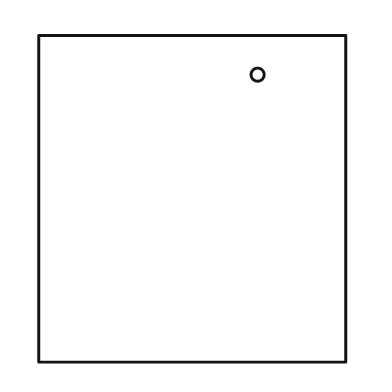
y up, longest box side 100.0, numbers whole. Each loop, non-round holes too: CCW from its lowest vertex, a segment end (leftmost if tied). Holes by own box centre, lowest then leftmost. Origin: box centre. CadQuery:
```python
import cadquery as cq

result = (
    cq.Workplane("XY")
    .moveTo(-47.0, -50.0)
    .lineTo(47.0, -50.0)
    .lineTo(47.0, 50.0)
    .lineTo(-47.0, 50.0)
    .close()
    .moveTo(20.0, 38.0)
    .circle(2.0)
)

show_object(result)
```